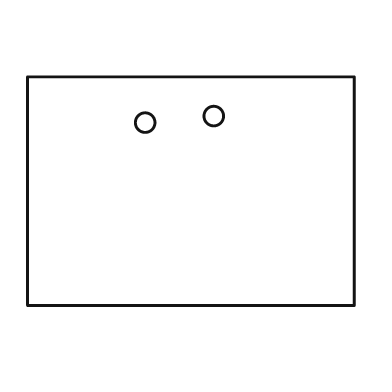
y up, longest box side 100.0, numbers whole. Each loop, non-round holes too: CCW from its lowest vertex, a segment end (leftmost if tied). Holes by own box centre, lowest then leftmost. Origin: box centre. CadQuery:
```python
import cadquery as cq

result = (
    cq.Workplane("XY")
    .moveTo(-50.0, -35.0)
    .lineTo(50.0, -35.0)
    .lineTo(50.0, 35.0)
    .lineTo(-50.0, 35.0)
    .close()
    .moveTo(-14.0, 21.0)
    .circle(3.0)
    .moveTo(7.0, 23.0)
    .circle(3.0)
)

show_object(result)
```